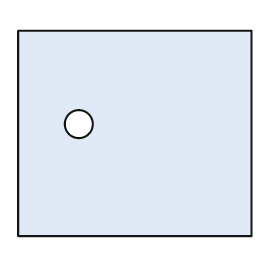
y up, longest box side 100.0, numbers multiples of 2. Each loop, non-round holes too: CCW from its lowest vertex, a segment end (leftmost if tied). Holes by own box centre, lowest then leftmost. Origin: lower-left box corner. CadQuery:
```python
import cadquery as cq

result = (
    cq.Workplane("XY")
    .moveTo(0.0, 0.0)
    .lineTo(100.0, 0.0)
    .lineTo(100.0, 88.0)
    .lineTo(0.0, 88.0)
    .close()
    .moveTo(26.0, 48.0)
    .circle(6.0)
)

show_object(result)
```